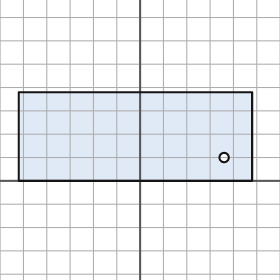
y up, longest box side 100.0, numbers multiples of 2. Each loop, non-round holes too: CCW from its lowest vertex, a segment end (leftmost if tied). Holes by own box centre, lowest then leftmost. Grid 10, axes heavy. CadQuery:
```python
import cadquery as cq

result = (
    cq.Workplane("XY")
    .moveTo(-52.0, 0.0)
    .lineTo(48.0, 0.0)
    .lineTo(48.0, 38.0)
    .lineTo(-52.0, 38.0)
    .close()
    .moveTo(36.0, 10.0)
    .circle(2.0)
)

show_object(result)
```